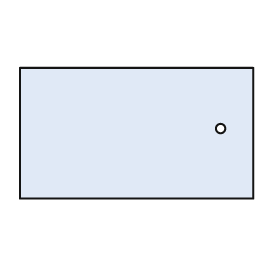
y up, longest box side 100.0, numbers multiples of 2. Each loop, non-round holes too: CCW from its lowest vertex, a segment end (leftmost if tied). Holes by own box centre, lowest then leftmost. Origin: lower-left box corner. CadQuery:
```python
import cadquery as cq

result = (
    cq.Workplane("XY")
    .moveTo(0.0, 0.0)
    .lineTo(100.0, 0.0)
    .lineTo(100.0, 56.0)
    .lineTo(0.0, 56.0)
    .close()
    .moveTo(86.0, 30.0)
    .circle(2.0)
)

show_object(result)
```